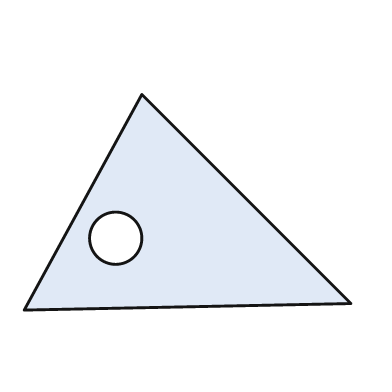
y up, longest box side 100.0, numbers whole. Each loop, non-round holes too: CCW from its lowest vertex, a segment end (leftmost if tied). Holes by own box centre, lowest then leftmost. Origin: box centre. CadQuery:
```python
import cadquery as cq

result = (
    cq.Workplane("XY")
    .moveTo(-50.0, -33.0)
    .lineTo(50.0, -31.0)
    .lineTo(-14.0, 33.0)
    .close()
    .moveTo(-22.0, -11.0)
    .circle(8.0)
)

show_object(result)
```